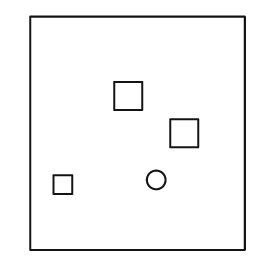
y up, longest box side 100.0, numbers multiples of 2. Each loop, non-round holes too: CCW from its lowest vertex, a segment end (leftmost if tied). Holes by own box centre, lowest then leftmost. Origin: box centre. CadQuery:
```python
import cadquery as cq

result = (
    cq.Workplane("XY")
    .moveTo(-46.0, -50.0)
    .lineTo(46.0, -50.0)
    .lineTo(46.0, 50.0)
    .lineTo(-46.0, 50.0)
    .close()
    .moveTo(-36.0, -26.0)
    .lineTo(-28.0, -26.0)
    .lineTo(-28.0, -18.0)
    .lineTo(-36.0, -18.0)
    .close()
    .moveTo(8.0, -20.0)
    .circle(4.0)
    .moveTo(14.0, -6.0)
    .lineTo(26.0, -6.0)
    .lineTo(26.0, 6.0)
    .lineTo(14.0, 6.0)
    .close()
    .moveTo(-10.0, 10.0)
    .lineTo(2.0, 10.0)
    .lineTo(2.0, 22.0)
    .lineTo(-10.0, 22.0)
    .close()
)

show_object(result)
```